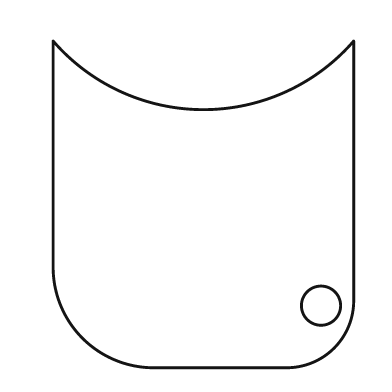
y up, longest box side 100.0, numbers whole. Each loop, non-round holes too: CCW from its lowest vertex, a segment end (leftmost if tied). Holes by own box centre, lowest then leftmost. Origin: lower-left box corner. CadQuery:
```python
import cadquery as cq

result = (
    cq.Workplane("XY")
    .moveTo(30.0, 0.0)
    .lineTo(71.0, 0.0)
    .threePointArc((86.0, 6.0), (92.0, 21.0))
    .lineTo(92.0, 100.0)
    .threePointArc((46.0, 79.0), (0.0, 100.0))
    .lineTo(0.0, 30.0)
    .threePointArc((9.0, 9.0), (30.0, 0.0))
    .close()
    .moveTo(82.0, 19.0)
    .circle(6.0)
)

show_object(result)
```